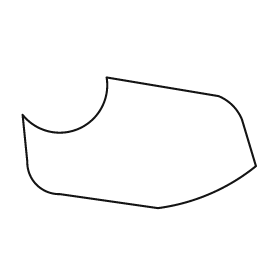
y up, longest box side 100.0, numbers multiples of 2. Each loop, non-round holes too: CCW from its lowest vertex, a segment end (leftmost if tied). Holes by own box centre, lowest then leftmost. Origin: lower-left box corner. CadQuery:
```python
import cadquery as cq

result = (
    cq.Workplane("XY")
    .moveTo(58.0, 0.0)
    .threePointArc((80.0, 6.0), (100.0, 18.0))
    .lineTo(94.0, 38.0)
    .threePointArc((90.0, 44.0), (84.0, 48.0))
    .lineTo(36.0, 56.0)
    .threePointArc((24.0, 34.0), (0.0, 40.0))
    .lineTo(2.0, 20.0)
    .threePointArc((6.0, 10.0), (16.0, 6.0))
    .close()
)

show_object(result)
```